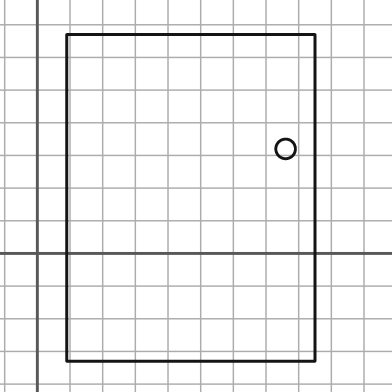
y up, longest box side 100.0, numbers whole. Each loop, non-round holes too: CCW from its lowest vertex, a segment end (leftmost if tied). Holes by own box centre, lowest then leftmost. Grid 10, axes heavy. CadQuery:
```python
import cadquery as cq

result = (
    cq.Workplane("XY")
    .moveTo(9.0, -33.0)
    .lineTo(85.0, -33.0)
    .lineTo(85.0, 67.0)
    .lineTo(9.0, 67.0)
    .close()
    .moveTo(76.0, 32.0)
    .circle(3.0)
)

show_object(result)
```